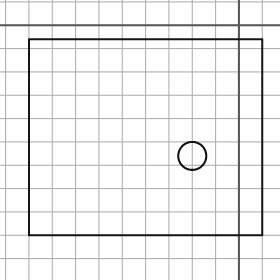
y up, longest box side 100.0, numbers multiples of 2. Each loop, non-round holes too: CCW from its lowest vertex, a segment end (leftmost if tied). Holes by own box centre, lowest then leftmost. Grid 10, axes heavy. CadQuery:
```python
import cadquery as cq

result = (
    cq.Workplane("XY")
    .moveTo(-90.0, -90.0)
    .lineTo(10.0, -90.0)
    .lineTo(10.0, -6.0)
    .lineTo(-90.0, -6.0)
    .close()
    .moveTo(-20.0, -56.0)
    .circle(6.0)
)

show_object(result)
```